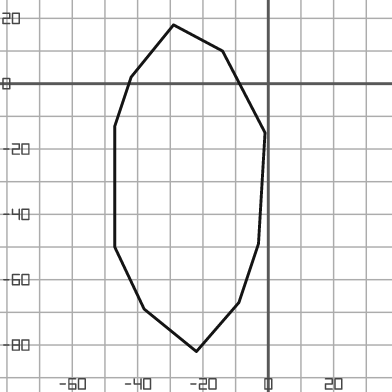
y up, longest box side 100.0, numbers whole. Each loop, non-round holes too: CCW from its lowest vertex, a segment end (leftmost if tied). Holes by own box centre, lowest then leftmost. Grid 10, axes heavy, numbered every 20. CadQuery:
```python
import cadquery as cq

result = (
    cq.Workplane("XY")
    .moveTo(-22.0, -82.0)
    .lineTo(-9.0, -67.0)
    .lineTo(-3.0, -49.0)
    .lineTo(-1.0, -15.0)
    .lineTo(-14.0, 10.0)
    .lineTo(-29.0, 18.0)
    .lineTo(-42.0, 2.0)
    .lineTo(-47.0, -13.0)
    .lineTo(-47.0, -50.0)
    .lineTo(-38.0, -69.0)
    .close()
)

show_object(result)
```